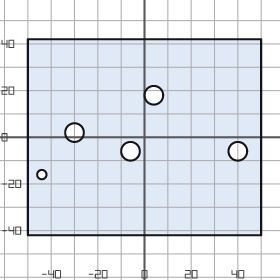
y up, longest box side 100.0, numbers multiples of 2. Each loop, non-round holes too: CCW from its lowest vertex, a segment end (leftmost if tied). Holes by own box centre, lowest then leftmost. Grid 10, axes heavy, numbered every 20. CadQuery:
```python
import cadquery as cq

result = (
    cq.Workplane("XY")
    .moveTo(-50.0, -42.0)
    .lineTo(50.0, -42.0)
    .lineTo(50.0, 42.0)
    .lineTo(-50.0, 42.0)
    .close()
    .moveTo(-44.0, -16.0)
    .circle(2.0)
    .moveTo(-6.0, -6.0)
    .circle(4.0)
    .moveTo(40.0, -6.0)
    .circle(4.0)
    .moveTo(-30.0, 2.0)
    .circle(4.0)
    .moveTo(4.0, 18.0)
    .circle(4.0)
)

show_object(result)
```